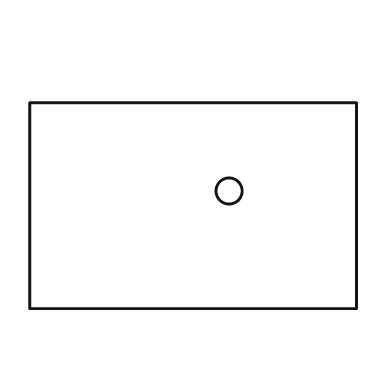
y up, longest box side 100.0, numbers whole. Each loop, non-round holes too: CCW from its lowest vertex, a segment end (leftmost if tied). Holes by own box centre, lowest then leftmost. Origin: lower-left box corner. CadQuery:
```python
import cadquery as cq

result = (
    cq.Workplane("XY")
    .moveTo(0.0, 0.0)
    .lineTo(100.0, 0.0)
    .lineTo(100.0, 63.0)
    .lineTo(0.0, 63.0)
    .close()
    .moveTo(61.0, 36.0)
    .circle(4.0)
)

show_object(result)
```